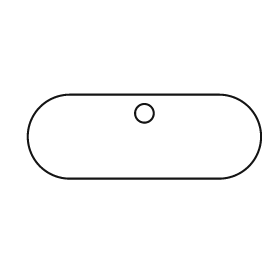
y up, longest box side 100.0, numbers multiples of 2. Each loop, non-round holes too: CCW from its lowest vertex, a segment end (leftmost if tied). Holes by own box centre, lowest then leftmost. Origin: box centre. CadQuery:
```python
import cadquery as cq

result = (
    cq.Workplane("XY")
    .moveTo(-32.0, -18.0)
    .lineTo(32.0, -18.0)
    .threePointArc((50.0, 0.0), (32.0, 18.0))
    .lineTo(-32.0, 18.0)
    .threePointArc((-50.0, 0.0), (-32.0, -18.0))
    .close()
    .moveTo(0.0, 10.0)
    .circle(4.0)
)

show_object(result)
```